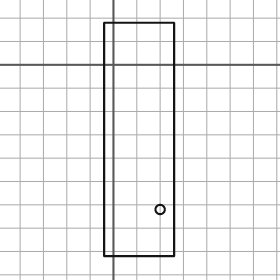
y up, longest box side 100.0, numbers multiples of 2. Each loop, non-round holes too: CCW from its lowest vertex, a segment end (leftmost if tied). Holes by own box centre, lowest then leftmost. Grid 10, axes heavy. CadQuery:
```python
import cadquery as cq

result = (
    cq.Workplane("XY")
    .moveTo(-4.0, -82.0)
    .lineTo(26.0, -82.0)
    .lineTo(26.0, 18.0)
    .lineTo(-4.0, 18.0)
    .close()
    .moveTo(20.0, -62.0)
    .circle(2.0)
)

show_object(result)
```